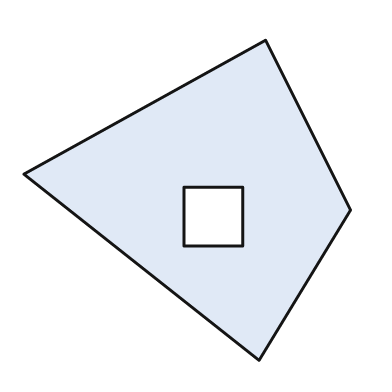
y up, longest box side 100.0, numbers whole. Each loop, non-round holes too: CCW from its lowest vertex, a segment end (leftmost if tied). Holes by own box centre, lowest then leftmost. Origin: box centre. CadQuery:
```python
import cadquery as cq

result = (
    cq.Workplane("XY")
    .moveTo(22.0, -49.0)
    .lineTo(50.0, -3.0)
    .lineTo(24.0, 49.0)
    .lineTo(-50.0, 8.0)
    .close()
    .moveTo(-1.0, -14.0)
    .lineTo(17.0, -14.0)
    .lineTo(17.0, 4.0)
    .lineTo(-1.0, 4.0)
    .close()
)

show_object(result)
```